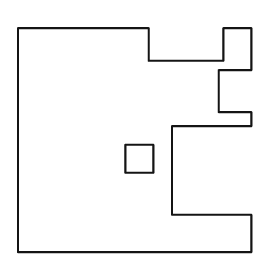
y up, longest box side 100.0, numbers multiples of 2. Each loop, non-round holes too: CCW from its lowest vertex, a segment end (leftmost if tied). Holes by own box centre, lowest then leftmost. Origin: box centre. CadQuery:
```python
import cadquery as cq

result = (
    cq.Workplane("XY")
    .moveTo(-50.0, -48.0)
    .lineTo(50.0, -48.0)
    .lineTo(50.0, -32.0)
    .lineTo(16.0, -32.0)
    .lineTo(16.0, 6.0)
    .lineTo(50.0, 6.0)
    .lineTo(50.0, 12.0)
    .lineTo(36.0, 12.0)
    .lineTo(36.0, 30.0)
    .lineTo(50.0, 30.0)
    .lineTo(50.0, 48.0)
    .lineTo(38.0, 48.0)
    .lineTo(38.0, 34.0)
    .lineTo(6.0, 34.0)
    .lineTo(6.0, 48.0)
    .lineTo(-50.0, 48.0)
    .close()
    .moveTo(-4.0, -14.0)
    .lineTo(8.0, -14.0)
    .lineTo(8.0, -2.0)
    .lineTo(-4.0, -2.0)
    .close()
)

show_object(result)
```